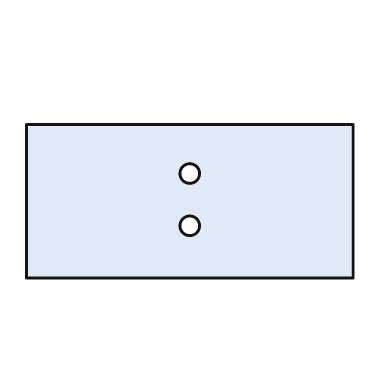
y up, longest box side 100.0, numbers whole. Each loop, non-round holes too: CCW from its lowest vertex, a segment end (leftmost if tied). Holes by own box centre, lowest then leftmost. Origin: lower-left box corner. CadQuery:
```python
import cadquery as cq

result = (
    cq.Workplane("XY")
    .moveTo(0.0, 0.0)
    .lineTo(100.0, 0.0)
    .lineTo(100.0, 47.0)
    .lineTo(0.0, 47.0)
    .close()
    .moveTo(50.0, 16.0)
    .circle(3.0)
    .moveTo(50.0, 32.0)
    .circle(3.0)
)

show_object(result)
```